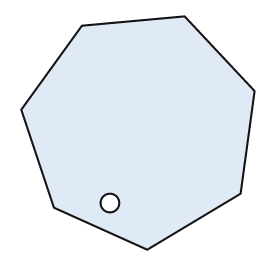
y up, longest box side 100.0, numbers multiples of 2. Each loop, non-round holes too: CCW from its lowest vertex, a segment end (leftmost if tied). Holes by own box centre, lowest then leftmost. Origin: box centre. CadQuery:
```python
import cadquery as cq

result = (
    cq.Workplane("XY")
    .moveTo(4.0, -50.0)
    .lineTo(44.0, -26.0)
    .lineTo(50.0, 18.0)
    .lineTo(20.0, 50.0)
    .lineTo(-24.0, 46.0)
    .lineTo(-50.0, 10.0)
    .lineTo(-36.0, -32.0)
    .close()
    .moveTo(-12.0, -30.0)
    .circle(4.0)
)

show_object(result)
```